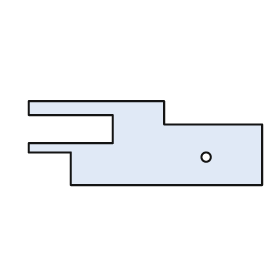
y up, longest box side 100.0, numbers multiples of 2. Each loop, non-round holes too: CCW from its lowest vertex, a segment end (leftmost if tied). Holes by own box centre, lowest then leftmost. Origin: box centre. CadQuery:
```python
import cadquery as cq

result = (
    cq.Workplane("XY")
    .moveTo(-32.0, -18.0)
    .lineTo(50.0, -18.0)
    .lineTo(50.0, 8.0)
    .lineTo(8.0, 8.0)
    .lineTo(8.0, 18.0)
    .lineTo(-50.0, 18.0)
    .lineTo(-50.0, 12.0)
    .lineTo(-14.0, 12.0)
    .lineTo(-14.0, 0.0)
    .lineTo(-50.0, 0.0)
    .lineTo(-50.0, -4.0)
    .lineTo(-32.0, -4.0)
    .close()
    .moveTo(26.0, -6.0)
    .circle(2.0)
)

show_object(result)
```